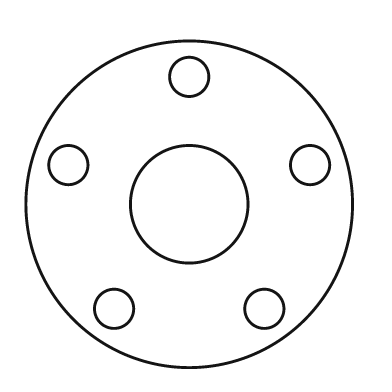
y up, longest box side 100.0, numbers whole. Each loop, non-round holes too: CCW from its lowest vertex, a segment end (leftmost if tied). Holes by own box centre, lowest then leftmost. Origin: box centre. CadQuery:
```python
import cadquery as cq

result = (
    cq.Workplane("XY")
    .moveTo(0.0, 0.0)
    .circle(50.0)
    .moveTo(-23.0, -32.0)
    .circle(6.0)
    .moveTo(23.0, -32.0)
    .circle(6.0)
    .moveTo(0.0, 0.0)
    .circle(18.0)
    .moveTo(-37.0, 12.0)
    .circle(6.0)
    .moveTo(37.0, 12.0)
    .circle(6.0)
    .moveTo(0.0, 39.0)
    .circle(6.0)
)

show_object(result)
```